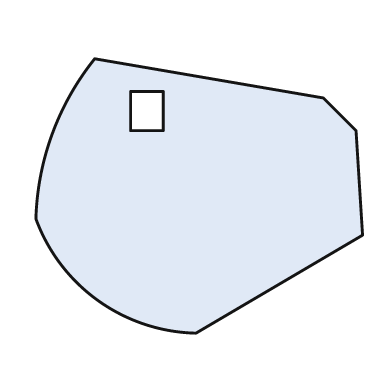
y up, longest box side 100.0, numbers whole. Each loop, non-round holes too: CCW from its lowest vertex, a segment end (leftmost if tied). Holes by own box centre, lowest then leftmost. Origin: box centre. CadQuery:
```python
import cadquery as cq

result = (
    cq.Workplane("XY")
    .moveTo(-1.0, -42.0)
    .lineTo(50.0, -12.0)
    .lineTo(48.0, 20.0)
    .lineTo(38.0, 30.0)
    .lineTo(-32.0, 42.0)
    .threePointArc((-45.0, 19.0), (-50.0, -7.0))
    .threePointArc((-31.0, -32.0), (-1.0, -42.0))
    .close()
    .moveTo(-21.0, 20.0)
    .lineTo(-11.0, 20.0)
    .lineTo(-11.0, 32.0)
    .lineTo(-21.0, 32.0)
    .close()
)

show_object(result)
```